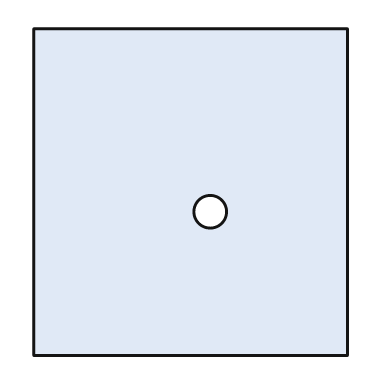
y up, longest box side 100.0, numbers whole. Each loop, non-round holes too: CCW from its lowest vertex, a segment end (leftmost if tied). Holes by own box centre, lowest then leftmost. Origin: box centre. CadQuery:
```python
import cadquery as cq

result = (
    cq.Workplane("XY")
    .moveTo(-48.0, -50.0)
    .lineTo(48.0, -50.0)
    .lineTo(48.0, 50.0)
    .lineTo(-48.0, 50.0)
    .close()
    .moveTo(6.0, -6.0)
    .circle(5.0)
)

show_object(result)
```